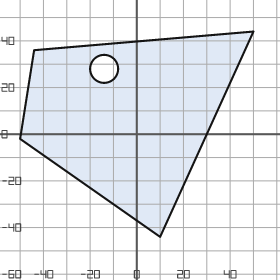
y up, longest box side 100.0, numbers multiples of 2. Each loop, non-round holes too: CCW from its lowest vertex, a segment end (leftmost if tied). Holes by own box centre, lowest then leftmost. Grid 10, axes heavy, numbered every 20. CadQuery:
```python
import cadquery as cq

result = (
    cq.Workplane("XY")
    .moveTo(10.0, -44.0)
    .lineTo(50.0, 44.0)
    .lineTo(-44.0, 36.0)
    .lineTo(-50.0, -2.0)
    .close()
    .moveTo(-14.0, 28.0)
    .circle(6.0)
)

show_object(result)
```